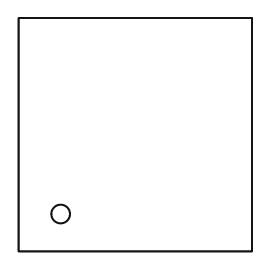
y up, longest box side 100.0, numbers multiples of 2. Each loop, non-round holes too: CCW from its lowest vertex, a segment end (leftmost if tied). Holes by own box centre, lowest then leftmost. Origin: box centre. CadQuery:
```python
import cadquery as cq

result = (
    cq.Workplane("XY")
    .moveTo(-50.0, -50.0)
    .lineTo(50.0, -50.0)
    .lineTo(50.0, 50.0)
    .lineTo(-50.0, 50.0)
    .close()
    .moveTo(-32.0, -34.0)
    .circle(4.0)
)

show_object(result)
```